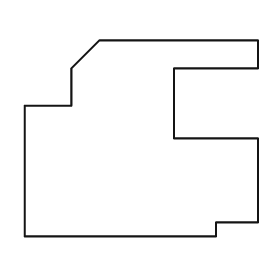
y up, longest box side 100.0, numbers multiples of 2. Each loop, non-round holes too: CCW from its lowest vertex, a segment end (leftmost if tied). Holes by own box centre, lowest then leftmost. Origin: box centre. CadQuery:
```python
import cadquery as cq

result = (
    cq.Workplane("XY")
    .moveTo(-50.0, -42.0)
    .lineTo(32.0, -42.0)
    .lineTo(32.0, -36.0)
    .lineTo(50.0, -36.0)
    .lineTo(50.0, 0.0)
    .lineTo(14.0, 0.0)
    .lineTo(14.0, 30.0)
    .lineTo(50.0, 30.0)
    .lineTo(50.0, 42.0)
    .lineTo(-18.0, 42.0)
    .lineTo(-30.0, 30.0)
    .lineTo(-30.0, 14.0)
    .lineTo(-50.0, 14.0)
    .close()
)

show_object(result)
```